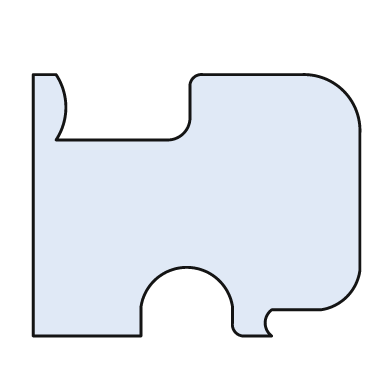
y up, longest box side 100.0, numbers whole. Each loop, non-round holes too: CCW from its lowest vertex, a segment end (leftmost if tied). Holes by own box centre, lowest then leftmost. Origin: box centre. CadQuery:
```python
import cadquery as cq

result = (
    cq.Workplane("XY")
    .moveTo(-50.0, -40.0)
    .lineTo(-17.0, -40.0)
    .lineTo(-17.0, -31.0)
    .threePointArc((-3.0, -19.0), (11.0, -31.0))
    .lineTo(11.0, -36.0)
    .threePointArc((12.0, -39.0), (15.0, -40.0))
    .lineTo(23.0, -40.0)
    .threePointArc((21.0, -36.0), (23.0, -32.0))
    .lineTo(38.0, -32.0)
    .threePointArc((46.0, -28.0), (50.0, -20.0))
    .lineTo(50.0, 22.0)
    .threePointArc((45.0, 35.0), (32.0, 40.0))
    .lineTo(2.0, 40.0)
    .threePointArc((-1.0, 39.0), (-2.0, 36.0))
    .lineTo(-2.0, 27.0)
    .threePointArc((-4.0, 22.0), (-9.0, 20.0))
    .lineTo(-43.0, 20.0)
    .threePointArc((-40.0, 30.0), (-43.0, 40.0))
    .lineTo(-50.0, 40.0)
    .close()
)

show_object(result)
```